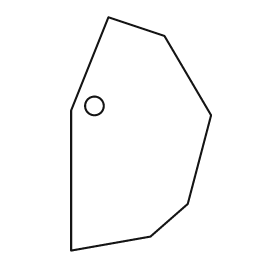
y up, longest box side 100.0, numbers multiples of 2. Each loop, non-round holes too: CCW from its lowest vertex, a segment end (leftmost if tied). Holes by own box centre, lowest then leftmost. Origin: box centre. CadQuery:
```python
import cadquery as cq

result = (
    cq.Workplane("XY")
    .moveTo(-30.0, -50.0)
    .lineTo(4.0, -44.0)
    .lineTo(20.0, -30.0)
    .lineTo(30.0, 8.0)
    .lineTo(10.0, 42.0)
    .lineTo(-14.0, 50.0)
    .lineTo(-30.0, 10.0)
    .close()
    .moveTo(-20.0, 12.0)
    .circle(4.0)
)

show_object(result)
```